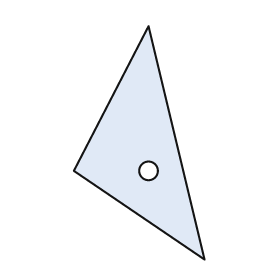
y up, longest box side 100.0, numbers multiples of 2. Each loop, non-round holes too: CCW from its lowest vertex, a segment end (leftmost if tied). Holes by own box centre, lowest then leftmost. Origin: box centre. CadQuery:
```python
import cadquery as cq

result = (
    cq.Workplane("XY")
    .moveTo(28.0, -50.0)
    .lineTo(4.0, 50.0)
    .lineTo(-28.0, -12.0)
    .close()
    .moveTo(4.0, -12.0)
    .circle(4.0)
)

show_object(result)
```